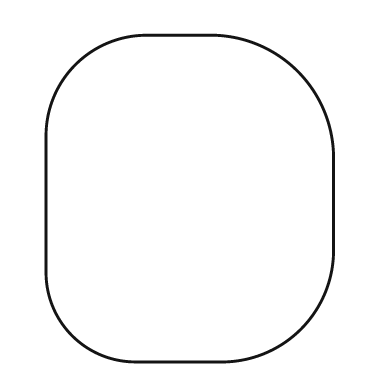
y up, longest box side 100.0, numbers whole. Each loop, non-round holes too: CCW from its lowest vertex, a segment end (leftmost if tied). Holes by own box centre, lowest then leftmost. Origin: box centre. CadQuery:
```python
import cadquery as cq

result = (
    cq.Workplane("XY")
    .moveTo(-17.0, -50.0)
    .lineTo(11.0, -50.0)
    .threePointArc((34.0, -40.0), (44.0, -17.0))
    .lineTo(44.0, 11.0)
    .threePointArc((33.0, 39.0), (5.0, 50.0))
    .lineTo(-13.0, 50.0)
    .threePointArc((-35.0, 41.0), (-44.0, 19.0))
    .lineTo(-44.0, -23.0)
    .threePointArc((-36.0, -42.0), (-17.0, -50.0))
    .close()
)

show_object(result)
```